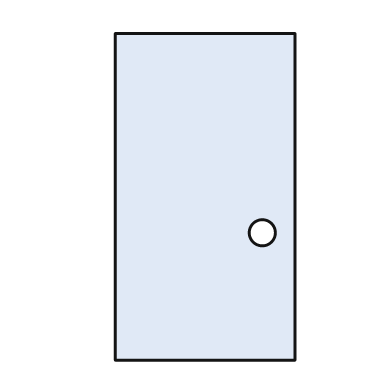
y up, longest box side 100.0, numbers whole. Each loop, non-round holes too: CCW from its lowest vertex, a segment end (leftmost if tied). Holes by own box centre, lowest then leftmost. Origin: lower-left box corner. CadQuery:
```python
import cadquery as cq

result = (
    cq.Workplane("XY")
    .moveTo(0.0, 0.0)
    .lineTo(55.0, 0.0)
    .lineTo(55.0, 100.0)
    .lineTo(0.0, 100.0)
    .close()
    .moveTo(45.0, 39.0)
    .circle(4.0)
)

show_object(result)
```